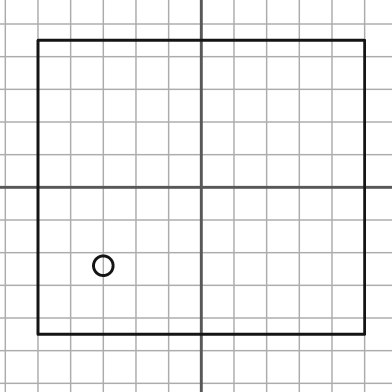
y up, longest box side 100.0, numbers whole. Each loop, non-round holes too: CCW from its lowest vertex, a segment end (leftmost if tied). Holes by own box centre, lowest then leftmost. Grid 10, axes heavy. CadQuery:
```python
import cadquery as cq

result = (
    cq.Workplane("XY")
    .moveTo(-50.0, -45.0)
    .lineTo(50.0, -45.0)
    .lineTo(50.0, 45.0)
    .lineTo(-50.0, 45.0)
    .close()
    .moveTo(-30.0, -24.0)
    .circle(3.0)
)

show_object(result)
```